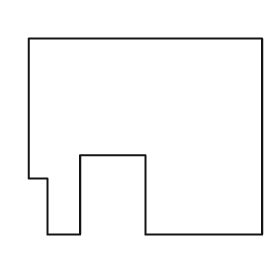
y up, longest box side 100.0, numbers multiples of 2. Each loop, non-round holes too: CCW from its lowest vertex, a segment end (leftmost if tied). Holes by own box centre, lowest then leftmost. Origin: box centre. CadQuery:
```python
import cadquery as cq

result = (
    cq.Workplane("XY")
    .moveTo(-42.0, -42.0)
    .lineTo(-28.0, -42.0)
    .lineTo(-28.0, -8.0)
    .lineTo(0.0, -8.0)
    .lineTo(0.0, -42.0)
    .lineTo(50.0, -42.0)
    .lineTo(50.0, 42.0)
    .lineTo(-50.0, 42.0)
    .lineTo(-50.0, -18.0)
    .lineTo(-42.0, -18.0)
    .close()
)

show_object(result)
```